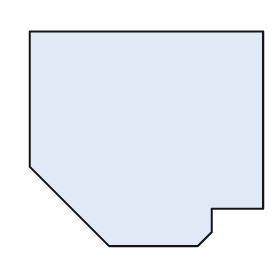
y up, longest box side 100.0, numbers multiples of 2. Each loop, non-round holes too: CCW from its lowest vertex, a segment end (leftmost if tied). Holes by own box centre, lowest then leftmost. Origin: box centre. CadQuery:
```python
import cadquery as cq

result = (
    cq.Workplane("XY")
    .moveTo(-16.0, -46.0)
    .lineTo(22.0, -46.0)
    .lineTo(28.0, -40.0)
    .lineTo(28.0, -30.0)
    .lineTo(50.0, -30.0)
    .lineTo(50.0, 46.0)
    .lineTo(-50.0, 46.0)
    .lineTo(-50.0, -12.0)
    .close()
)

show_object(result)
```